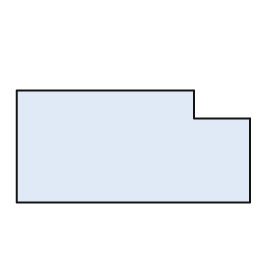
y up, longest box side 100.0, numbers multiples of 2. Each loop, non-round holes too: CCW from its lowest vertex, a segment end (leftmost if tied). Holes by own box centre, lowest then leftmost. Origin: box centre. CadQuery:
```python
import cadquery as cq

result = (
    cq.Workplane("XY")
    .moveTo(-50.0, -24.0)
    .lineTo(50.0, -24.0)
    .lineTo(50.0, 12.0)
    .lineTo(26.0, 12.0)
    .lineTo(26.0, 24.0)
    .lineTo(-50.0, 24.0)
    .close()
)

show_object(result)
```